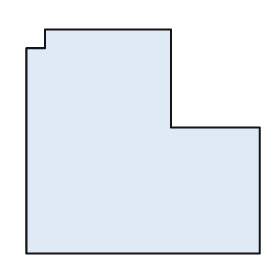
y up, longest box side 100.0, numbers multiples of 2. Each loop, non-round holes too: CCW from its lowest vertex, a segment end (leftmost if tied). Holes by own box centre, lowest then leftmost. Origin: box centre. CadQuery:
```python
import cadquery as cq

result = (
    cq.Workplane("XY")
    .moveTo(-50.0, -48.0)
    .lineTo(50.0, -48.0)
    .lineTo(50.0, 6.0)
    .lineTo(12.0, 6.0)
    .lineTo(12.0, 48.0)
    .lineTo(-42.0, 48.0)
    .lineTo(-42.0, 40.0)
    .lineTo(-50.0, 40.0)
    .close()
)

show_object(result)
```